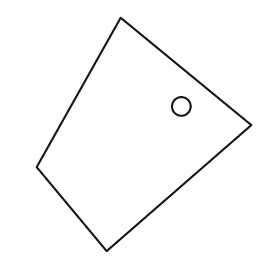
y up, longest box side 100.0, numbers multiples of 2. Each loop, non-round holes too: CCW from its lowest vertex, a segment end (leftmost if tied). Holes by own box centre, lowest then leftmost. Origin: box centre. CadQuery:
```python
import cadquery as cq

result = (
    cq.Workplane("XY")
    .moveTo(-16.0, -50.0)
    .lineTo(46.0, 4.0)
    .lineTo(-10.0, 50.0)
    .lineTo(-46.0, -14.0)
    .close()
    .moveTo(16.0, 12.0)
    .circle(4.0)
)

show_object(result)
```